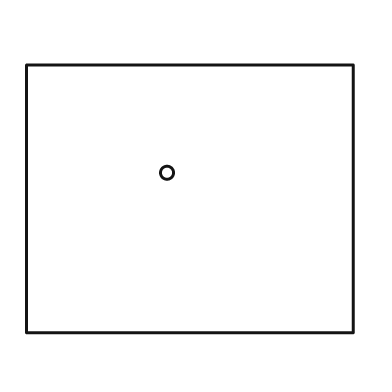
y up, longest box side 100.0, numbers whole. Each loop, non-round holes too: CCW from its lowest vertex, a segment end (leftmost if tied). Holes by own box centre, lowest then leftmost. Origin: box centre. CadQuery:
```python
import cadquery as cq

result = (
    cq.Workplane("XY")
    .moveTo(-50.0, -41.0)
    .lineTo(50.0, -41.0)
    .lineTo(50.0, 41.0)
    .lineTo(-50.0, 41.0)
    .close()
    .moveTo(-7.0, 8.0)
    .circle(2.0)
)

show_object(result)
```